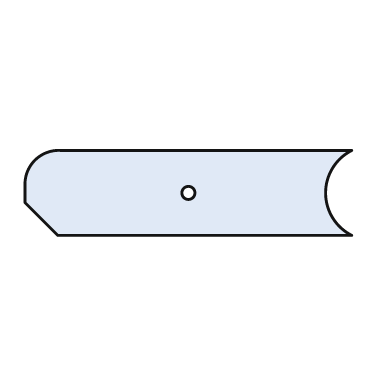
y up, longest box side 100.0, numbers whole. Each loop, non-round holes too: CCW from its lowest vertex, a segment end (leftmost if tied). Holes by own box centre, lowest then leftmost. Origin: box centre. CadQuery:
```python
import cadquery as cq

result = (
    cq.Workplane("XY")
    .moveTo(-40.0, -13.0)
    .lineTo(50.0, -13.0)
    .threePointArc((42.0, 0.0), (50.0, 13.0))
    .lineTo(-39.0, 13.0)
    .threePointArc((-47.0, 10.0), (-50.0, 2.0))
    .lineTo(-50.0, -3.0)
    .close()
    .moveTo(0.0, 0.0)
    .circle(2.0)
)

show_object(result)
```